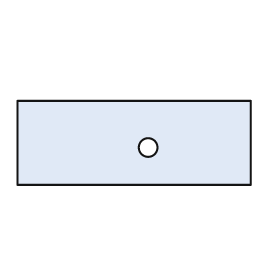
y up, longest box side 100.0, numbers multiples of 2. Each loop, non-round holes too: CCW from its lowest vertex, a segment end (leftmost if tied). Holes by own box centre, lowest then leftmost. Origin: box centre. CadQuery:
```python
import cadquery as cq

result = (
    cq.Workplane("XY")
    .moveTo(-50.0, -18.0)
    .lineTo(50.0, -18.0)
    .lineTo(50.0, 18.0)
    .lineTo(-50.0, 18.0)
    .close()
    .moveTo(6.0, -2.0)
    .circle(4.0)
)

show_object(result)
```